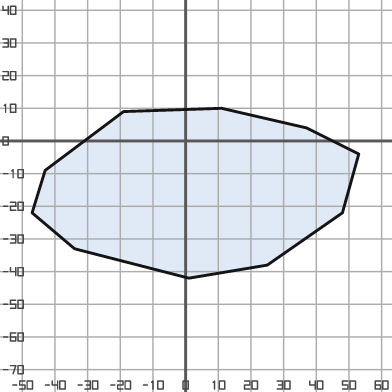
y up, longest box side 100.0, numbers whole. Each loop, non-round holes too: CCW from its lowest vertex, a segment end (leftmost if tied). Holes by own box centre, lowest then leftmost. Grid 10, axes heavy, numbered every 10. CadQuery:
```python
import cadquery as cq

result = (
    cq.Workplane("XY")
    .moveTo(1.0, -42.0)
    .lineTo(25.0, -38.0)
    .lineTo(48.0, -22.0)
    .lineTo(53.0, -4.0)
    .lineTo(37.0, 4.0)
    .lineTo(11.0, 10.0)
    .lineTo(-19.0, 9.0)
    .lineTo(-43.0, -9.0)
    .lineTo(-47.0, -22.0)
    .lineTo(-34.0, -33.0)
    .close()
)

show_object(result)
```